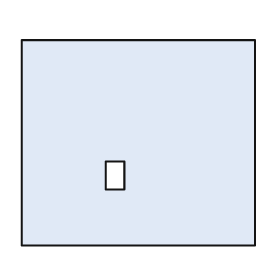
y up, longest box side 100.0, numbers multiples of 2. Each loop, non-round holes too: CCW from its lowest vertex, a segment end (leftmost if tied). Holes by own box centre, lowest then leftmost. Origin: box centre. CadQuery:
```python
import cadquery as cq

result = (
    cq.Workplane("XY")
    .moveTo(-50.0, -44.0)
    .lineTo(50.0, -44.0)
    .lineTo(50.0, 44.0)
    .lineTo(-50.0, 44.0)
    .close()
    .moveTo(-14.0, -20.0)
    .lineTo(-6.0, -20.0)
    .lineTo(-6.0, -8.0)
    .lineTo(-14.0, -8.0)
    .close()
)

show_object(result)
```